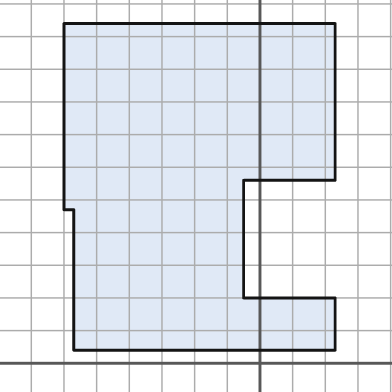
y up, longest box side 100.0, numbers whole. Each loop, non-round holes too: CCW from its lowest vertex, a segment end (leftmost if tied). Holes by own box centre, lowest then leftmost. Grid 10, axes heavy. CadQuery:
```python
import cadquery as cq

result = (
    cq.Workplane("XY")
    .moveTo(-57.0, 4.0)
    .lineTo(23.0, 4.0)
    .lineTo(23.0, 20.0)
    .lineTo(-5.0, 20.0)
    .lineTo(-5.0, 56.0)
    .lineTo(23.0, 56.0)
    .lineTo(23.0, 104.0)
    .lineTo(-60.0, 104.0)
    .lineTo(-60.0, 47.0)
    .lineTo(-57.0, 47.0)
    .close()
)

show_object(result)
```